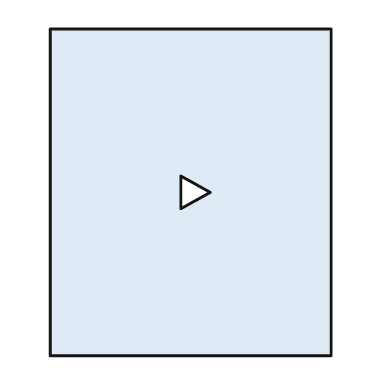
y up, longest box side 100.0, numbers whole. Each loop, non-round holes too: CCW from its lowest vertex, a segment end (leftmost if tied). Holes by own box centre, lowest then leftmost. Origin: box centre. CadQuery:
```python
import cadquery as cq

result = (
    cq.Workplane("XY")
    .moveTo(-43.0, -50.0)
    .lineTo(43.0, -50.0)
    .lineTo(43.0, 50.0)
    .lineTo(-43.0, 50.0)
    .close()
    .moveTo(-3.0, -5.0)
    .lineTo(6.0, 0.0)
    .lineTo(-3.0, 5.0)
    .close()
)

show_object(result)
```